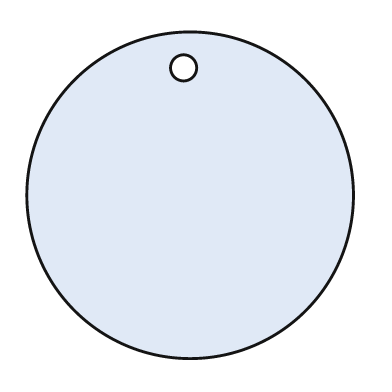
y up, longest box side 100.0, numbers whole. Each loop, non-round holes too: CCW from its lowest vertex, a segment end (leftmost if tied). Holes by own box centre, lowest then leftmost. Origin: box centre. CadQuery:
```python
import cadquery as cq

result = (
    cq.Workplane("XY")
    .moveTo(0.0, 0.0)
    .circle(50.0)
    .moveTo(-2.0, 39.0)
    .circle(4.0)
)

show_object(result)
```